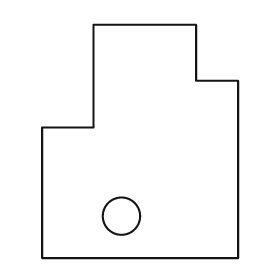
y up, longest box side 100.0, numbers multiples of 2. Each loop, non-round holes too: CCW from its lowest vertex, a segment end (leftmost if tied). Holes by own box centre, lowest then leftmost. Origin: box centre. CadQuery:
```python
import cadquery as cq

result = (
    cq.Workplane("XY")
    .moveTo(-42.0, -50.0)
    .lineTo(42.0, -50.0)
    .lineTo(42.0, 26.0)
    .lineTo(24.0, 26.0)
    .lineTo(24.0, 50.0)
    .lineTo(-20.0, 50.0)
    .lineTo(-20.0, 6.0)
    .lineTo(-42.0, 6.0)
    .close()
    .moveTo(-8.0, -32.0)
    .circle(8.0)
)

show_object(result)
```